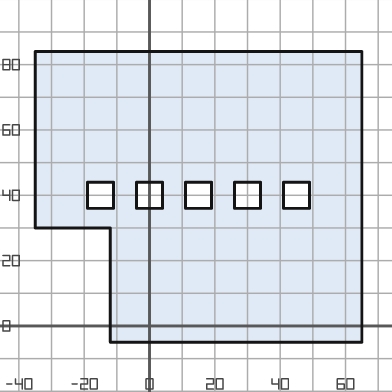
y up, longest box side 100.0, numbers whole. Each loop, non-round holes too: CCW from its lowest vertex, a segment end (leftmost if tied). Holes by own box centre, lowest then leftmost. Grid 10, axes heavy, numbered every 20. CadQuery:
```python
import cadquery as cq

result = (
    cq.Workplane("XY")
    .moveTo(-12.0, -5.0)
    .lineTo(65.0, -5.0)
    .lineTo(65.0, 84.0)
    .lineTo(-35.0, 84.0)
    .lineTo(-35.0, 30.0)
    .lineTo(-12.0, 30.0)
    .close()
    .moveTo(-19.0, 36.0)
    .lineTo(-11.0, 36.0)
    .lineTo(-11.0, 44.0)
    .lineTo(-19.0, 44.0)
    .close()
    .moveTo(-4.0, 36.0)
    .lineTo(4.0, 36.0)
    .lineTo(4.0, 44.0)
    .lineTo(-4.0, 44.0)
    .close()
    .moveTo(11.0, 36.0)
    .lineTo(19.0, 36.0)
    .lineTo(19.0, 44.0)
    .lineTo(11.0, 44.0)
    .close()
    .moveTo(26.0, 36.0)
    .lineTo(34.0, 36.0)
    .lineTo(34.0, 44.0)
    .lineTo(26.0, 44.0)
    .close()
    .moveTo(41.0, 36.0)
    .lineTo(49.0, 36.0)
    .lineTo(49.0, 44.0)
    .lineTo(41.0, 44.0)
    .close()
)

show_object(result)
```